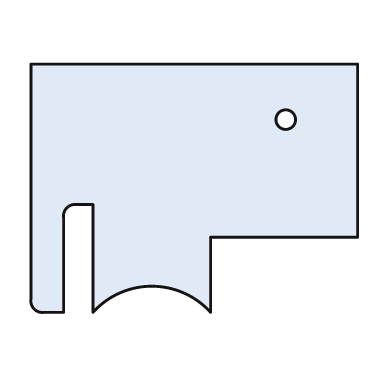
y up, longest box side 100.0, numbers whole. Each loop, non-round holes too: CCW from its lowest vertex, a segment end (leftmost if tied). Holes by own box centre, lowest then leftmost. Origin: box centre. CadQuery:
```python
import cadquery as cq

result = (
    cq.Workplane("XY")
    .moveTo(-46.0, -38.0)
    .lineTo(-40.0, -38.0)
    .lineTo(-40.0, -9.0)
    .threePointArc((-39.0, -6.0), (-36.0, -5.0))
    .lineTo(-31.0, -5.0)
    .lineTo(-31.0, -38.0)
    .threePointArc((-13.0, -30.0), (5.0, -38.0))
    .lineTo(5.0, -15.0)
    .lineTo(50.0, -15.0)
    .lineTo(50.0, 38.0)
    .lineTo(-50.0, 38.0)
    .lineTo(-50.0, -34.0)
    .threePointArc((-49.0, -37.0), (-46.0, -38.0))
    .close()
    .moveTo(28.0, 21.0)
    .circle(3.0)
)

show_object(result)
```